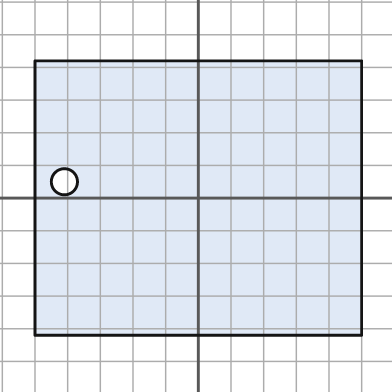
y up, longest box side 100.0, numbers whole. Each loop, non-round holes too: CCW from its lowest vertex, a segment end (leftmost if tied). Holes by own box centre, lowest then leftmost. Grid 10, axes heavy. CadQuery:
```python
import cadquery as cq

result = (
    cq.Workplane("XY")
    .moveTo(-50.0, -42.0)
    .lineTo(50.0, -42.0)
    .lineTo(50.0, 42.0)
    .lineTo(-50.0, 42.0)
    .close()
    .moveTo(-41.0, 5.0)
    .circle(4.0)
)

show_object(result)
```